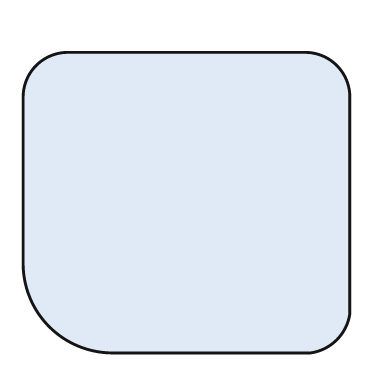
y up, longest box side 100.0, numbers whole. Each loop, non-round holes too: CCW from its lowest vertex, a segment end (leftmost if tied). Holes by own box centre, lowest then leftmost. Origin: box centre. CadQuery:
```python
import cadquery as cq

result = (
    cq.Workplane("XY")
    .moveTo(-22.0, -46.0)
    .lineTo(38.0, -46.0)
    .threePointArc((46.0, -42.0), (50.0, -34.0))
    .lineTo(50.0, 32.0)
    .threePointArc((46.0, 42.0), (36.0, 46.0))
    .lineTo(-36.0, 46.0)
    .threePointArc((-46.0, 42.0), (-50.0, 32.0))
    .lineTo(-50.0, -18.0)
    .threePointArc((-42.0, -38.0), (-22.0, -46.0))
    .close()
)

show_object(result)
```